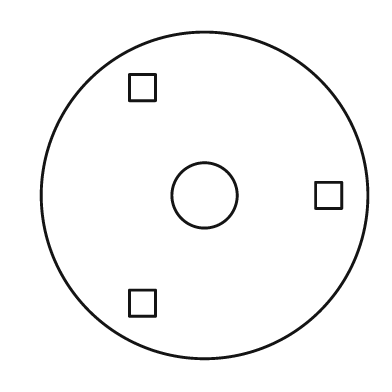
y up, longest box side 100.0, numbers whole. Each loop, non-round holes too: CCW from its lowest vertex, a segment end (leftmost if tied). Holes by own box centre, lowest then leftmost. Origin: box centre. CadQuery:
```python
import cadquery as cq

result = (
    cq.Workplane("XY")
    .moveTo(0.0, 0.0)
    .circle(50.0)
    .moveTo(-23.0, -37.0)
    .lineTo(-15.0, -37.0)
    .lineTo(-15.0, -29.0)
    .lineTo(-23.0, -29.0)
    .close()
    .moveTo(0.0, 0.0)
    .circle(10.0)
    .moveTo(34.0, -4.0)
    .lineTo(42.0, -4.0)
    .lineTo(42.0, 4.0)
    .lineTo(34.0, 4.0)
    .close()
    .moveTo(-23.0, 29.0)
    .lineTo(-15.0, 29.0)
    .lineTo(-15.0, 37.0)
    .lineTo(-23.0, 37.0)
    .close()
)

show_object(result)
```